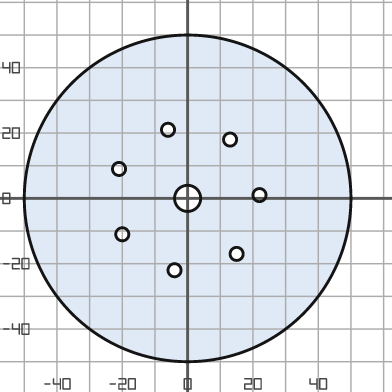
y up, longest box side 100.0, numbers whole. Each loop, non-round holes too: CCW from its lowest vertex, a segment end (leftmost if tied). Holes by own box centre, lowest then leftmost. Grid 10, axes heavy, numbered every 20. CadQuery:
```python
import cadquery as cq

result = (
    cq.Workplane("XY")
    .moveTo(0.0, 0.0)
    .circle(50.0)
    .moveTo(-4.0, -22.0)
    .circle(2.0)
    .moveTo(15.0, -17.0)
    .circle(2.0)
    .moveTo(-20.0, -11.0)
    .circle(2.0)
    .moveTo(0.0, 0.0)
    .circle(4.0)
    .moveTo(22.0, 1.0)
    .circle(2.0)
    .moveTo(-21.0, 9.0)
    .circle(2.0)
    .moveTo(13.0, 18.0)
    .circle(2.0)
    .moveTo(-6.0, 21.0)
    .circle(2.0)
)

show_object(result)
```